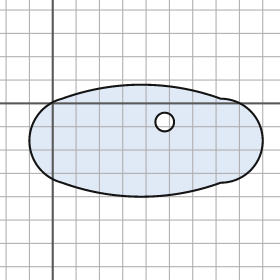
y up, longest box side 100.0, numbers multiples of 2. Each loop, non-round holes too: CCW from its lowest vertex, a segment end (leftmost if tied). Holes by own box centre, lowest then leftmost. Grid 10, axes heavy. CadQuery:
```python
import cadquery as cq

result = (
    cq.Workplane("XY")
    .moveTo(4.0, -34.0)
    .threePointArc((38.0, -40.0), (72.0, -34.0))
    .threePointArc((90.0, -16.0), (72.0, 2.0))
    .threePointArc((38.0, 8.0), (4.0, 2.0))
    .threePointArc((-10.0, -16.0), (4.0, -34.0))
    .close()
    .moveTo(48.0, -8.0)
    .circle(4.0)
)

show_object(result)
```